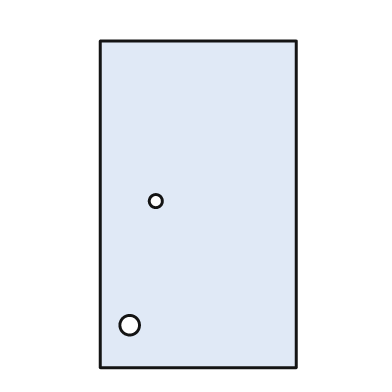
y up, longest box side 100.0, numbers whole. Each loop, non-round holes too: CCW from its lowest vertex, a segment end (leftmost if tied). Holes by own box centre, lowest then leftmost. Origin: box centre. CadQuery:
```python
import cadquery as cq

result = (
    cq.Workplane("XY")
    .moveTo(-30.0, -50.0)
    .lineTo(30.0, -50.0)
    .lineTo(30.0, 50.0)
    .lineTo(-30.0, 50.0)
    .close()
    .moveTo(-21.0, -37.0)
    .circle(3.0)
    .moveTo(-13.0, 1.0)
    .circle(2.0)
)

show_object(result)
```